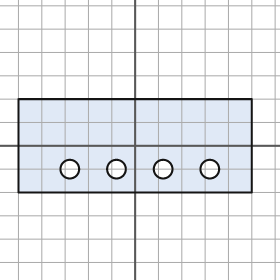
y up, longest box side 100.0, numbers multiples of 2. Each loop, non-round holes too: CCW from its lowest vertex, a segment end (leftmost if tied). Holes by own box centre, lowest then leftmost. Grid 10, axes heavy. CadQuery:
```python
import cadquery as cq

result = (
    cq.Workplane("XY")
    .moveTo(-50.0, -20.0)
    .lineTo(50.0, -20.0)
    .lineTo(50.0, 20.0)
    .lineTo(-50.0, 20.0)
    .close()
    .moveTo(-28.0, -10.0)
    .circle(4.0)
    .moveTo(-8.0, -10.0)
    .circle(4.0)
    .moveTo(12.0, -10.0)
    .circle(4.0)
    .moveTo(32.0, -10.0)
    .circle(4.0)
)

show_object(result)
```